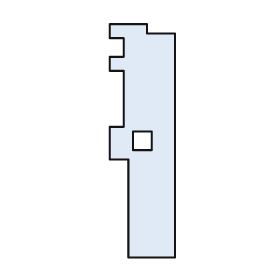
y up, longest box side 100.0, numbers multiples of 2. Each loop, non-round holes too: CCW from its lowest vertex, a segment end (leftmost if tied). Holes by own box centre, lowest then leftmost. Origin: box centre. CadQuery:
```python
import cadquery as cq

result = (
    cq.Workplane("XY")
    .moveTo(-6.0, -50.0)
    .lineTo(14.0, -50.0)
    .lineTo(14.0, 46.0)
    .lineTo(2.0, 46.0)
    .lineTo(2.0, 50.0)
    .lineTo(-14.0, 50.0)
    .lineTo(-14.0, 44.0)
    .lineTo(-8.0, 44.0)
    .lineTo(-8.0, 36.0)
    .lineTo(-14.0, 36.0)
    .lineTo(-14.0, 30.0)
    .lineTo(-8.0, 30.0)
    .lineTo(-8.0, 6.0)
    .lineTo(-14.0, 6.0)
    .lineTo(-14.0, -8.0)
    .lineTo(-6.0, -8.0)
    .close()
    .moveTo(-4.0, -4.0)
    .lineTo(4.0, -4.0)
    .lineTo(4.0, 4.0)
    .lineTo(-4.0, 4.0)
    .close()
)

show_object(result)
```